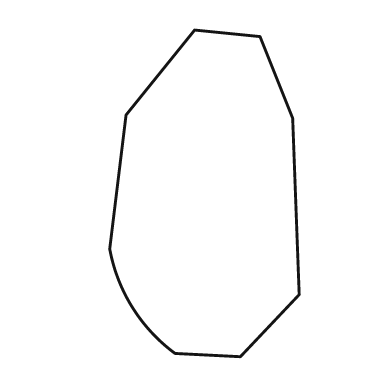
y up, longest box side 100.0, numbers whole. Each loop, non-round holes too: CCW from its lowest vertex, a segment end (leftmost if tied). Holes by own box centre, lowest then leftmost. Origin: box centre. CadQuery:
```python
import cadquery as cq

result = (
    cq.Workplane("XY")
    .moveTo(11.0, -50.0)
    .lineTo(29.0, -31.0)
    .lineTo(27.0, 23.0)
    .lineTo(17.0, 48.0)
    .lineTo(-3.0, 50.0)
    .lineTo(-24.0, 24.0)
    .lineTo(-29.0, -17.0)
    .threePointArc((-22.0, -35.0), (-9.0, -49.0))
    .close()
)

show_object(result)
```